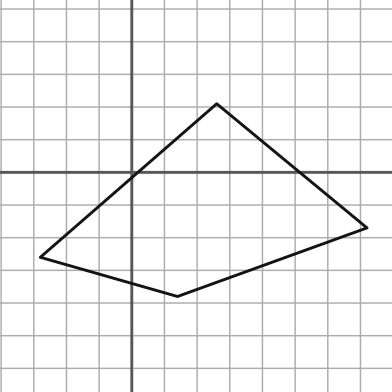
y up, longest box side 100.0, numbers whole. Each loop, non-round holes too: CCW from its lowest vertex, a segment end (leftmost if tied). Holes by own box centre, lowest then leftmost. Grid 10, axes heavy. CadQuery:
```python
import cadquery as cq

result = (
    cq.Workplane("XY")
    .moveTo(14.0, -38.0)
    .lineTo(72.0, -17.0)
    .lineTo(26.0, 21.0)
    .lineTo(-28.0, -26.0)
    .close()
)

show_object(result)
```